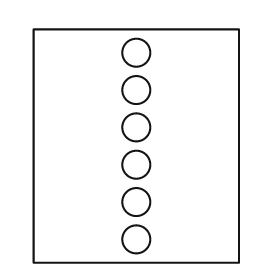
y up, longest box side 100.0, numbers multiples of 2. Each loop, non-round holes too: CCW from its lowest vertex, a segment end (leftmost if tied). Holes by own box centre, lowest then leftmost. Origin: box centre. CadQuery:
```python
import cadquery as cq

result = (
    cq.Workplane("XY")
    .moveTo(-44.0, -50.0)
    .lineTo(44.0, -50.0)
    .lineTo(44.0, 50.0)
    .lineTo(-44.0, 50.0)
    .close()
    .moveTo(0.0, -40.0)
    .circle(6.0)
    .moveTo(0.0, -24.0)
    .circle(6.0)
    .moveTo(0.0, -8.0)
    .circle(6.0)
    .moveTo(0.0, 8.0)
    .circle(6.0)
    .moveTo(0.0, 24.0)
    .circle(6.0)
    .moveTo(0.0, 40.0)
    .circle(6.0)
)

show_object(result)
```